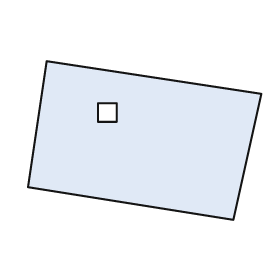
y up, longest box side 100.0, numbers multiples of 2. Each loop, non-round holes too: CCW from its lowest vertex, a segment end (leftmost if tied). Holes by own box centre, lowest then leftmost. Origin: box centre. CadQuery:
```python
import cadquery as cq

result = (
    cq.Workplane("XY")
    .moveTo(38.0, -34.0)
    .lineTo(50.0, 20.0)
    .lineTo(-42.0, 34.0)
    .lineTo(-50.0, -20.0)
    .close()
    .moveTo(-20.0, 8.0)
    .lineTo(-12.0, 8.0)
    .lineTo(-12.0, 16.0)
    .lineTo(-20.0, 16.0)
    .close()
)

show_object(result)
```